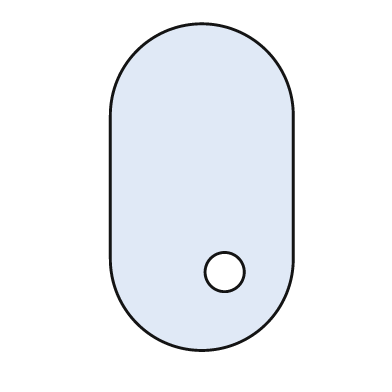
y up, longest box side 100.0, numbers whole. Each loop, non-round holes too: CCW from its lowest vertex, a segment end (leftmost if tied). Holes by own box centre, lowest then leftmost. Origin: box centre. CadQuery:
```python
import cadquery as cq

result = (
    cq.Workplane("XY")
    .moveTo(-28.0, -22.0)
    .threePointArc((0.0, -50.0), (28.0, -22.0))
    .lineTo(28.0, 22.0)
    .threePointArc((0.0, 50.0), (-28.0, 22.0))
    .close()
    .moveTo(7.0, -26.0)
    .circle(6.0)
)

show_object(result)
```